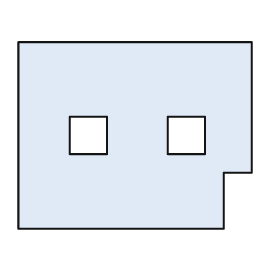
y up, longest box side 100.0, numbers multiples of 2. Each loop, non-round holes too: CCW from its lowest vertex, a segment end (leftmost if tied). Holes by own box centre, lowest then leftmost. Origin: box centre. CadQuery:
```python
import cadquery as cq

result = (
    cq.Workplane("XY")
    .moveTo(-50.0, -40.0)
    .lineTo(38.0, -40.0)
    .lineTo(38.0, -16.0)
    .lineTo(50.0, -16.0)
    .lineTo(50.0, 40.0)
    .lineTo(-50.0, 40.0)
    .close()
    .moveTo(-28.0, -8.0)
    .lineTo(-12.0, -8.0)
    .lineTo(-12.0, 8.0)
    .lineTo(-28.0, 8.0)
    .close()
    .moveTo(14.0, -8.0)
    .lineTo(30.0, -8.0)
    .lineTo(30.0, 8.0)
    .lineTo(14.0, 8.0)
    .close()
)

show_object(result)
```